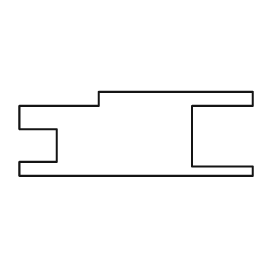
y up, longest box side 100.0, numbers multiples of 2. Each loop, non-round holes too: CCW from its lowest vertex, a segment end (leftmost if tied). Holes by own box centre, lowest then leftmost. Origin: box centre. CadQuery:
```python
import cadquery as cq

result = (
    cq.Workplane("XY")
    .moveTo(-50.0, -18.0)
    .lineTo(50.0, -18.0)
    .lineTo(50.0, -14.0)
    .lineTo(24.0, -14.0)
    .lineTo(24.0, 12.0)
    .lineTo(50.0, 12.0)
    .lineTo(50.0, 18.0)
    .lineTo(-16.0, 18.0)
    .lineTo(-16.0, 12.0)
    .lineTo(-50.0, 12.0)
    .lineTo(-50.0, 2.0)
    .lineTo(-34.0, 2.0)
    .lineTo(-34.0, -12.0)
    .lineTo(-50.0, -12.0)
    .close()
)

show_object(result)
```